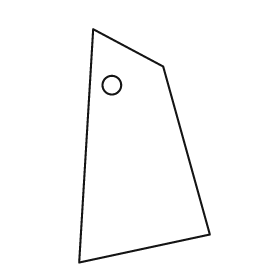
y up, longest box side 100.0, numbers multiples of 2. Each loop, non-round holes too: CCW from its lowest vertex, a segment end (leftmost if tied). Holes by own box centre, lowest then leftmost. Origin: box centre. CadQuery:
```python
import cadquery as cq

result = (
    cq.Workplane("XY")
    .moveTo(-28.0, -50.0)
    .lineTo(28.0, -38.0)
    .lineTo(8.0, 34.0)
    .lineTo(-22.0, 50.0)
    .close()
    .moveTo(-14.0, 26.0)
    .circle(4.0)
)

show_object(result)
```